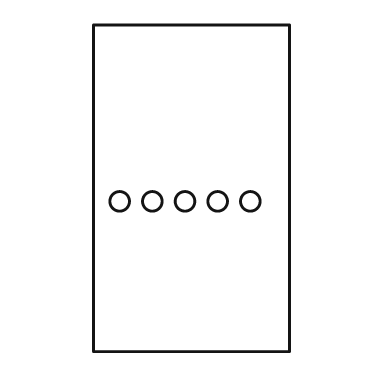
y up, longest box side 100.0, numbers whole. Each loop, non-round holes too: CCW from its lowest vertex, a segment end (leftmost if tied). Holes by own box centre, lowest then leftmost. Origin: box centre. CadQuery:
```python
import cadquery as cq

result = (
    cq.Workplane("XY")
    .moveTo(-30.0, -50.0)
    .lineTo(30.0, -50.0)
    .lineTo(30.0, 50.0)
    .lineTo(-30.0, 50.0)
    .close()
    .moveTo(-22.0, -4.0)
    .circle(3.0)
    .moveTo(-12.0, -4.0)
    .circle(3.0)
    .moveTo(-2.0, -4.0)
    .circle(3.0)
    .moveTo(8.0, -4.0)
    .circle(3.0)
    .moveTo(18.0, -4.0)
    .circle(3.0)
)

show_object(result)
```